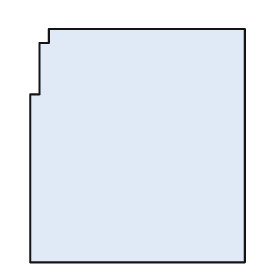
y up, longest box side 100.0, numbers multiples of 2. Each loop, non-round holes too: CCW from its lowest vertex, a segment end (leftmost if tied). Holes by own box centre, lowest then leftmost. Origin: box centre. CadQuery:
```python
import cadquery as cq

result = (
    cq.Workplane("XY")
    .moveTo(-46.0, -50.0)
    .lineTo(46.0, -50.0)
    .lineTo(46.0, 50.0)
    .lineTo(-38.0, 50.0)
    .lineTo(-38.0, 44.0)
    .lineTo(-42.0, 44.0)
    .lineTo(-42.0, 22.0)
    .lineTo(-46.0, 22.0)
    .close()
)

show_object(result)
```